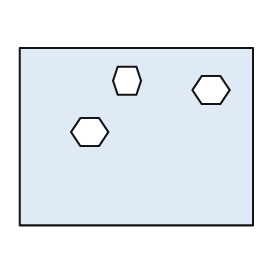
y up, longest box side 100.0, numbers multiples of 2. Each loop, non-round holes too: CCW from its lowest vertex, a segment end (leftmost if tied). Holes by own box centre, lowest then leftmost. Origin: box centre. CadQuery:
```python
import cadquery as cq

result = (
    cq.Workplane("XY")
    .moveTo(-50.0, -38.0)
    .lineTo(50.0, -38.0)
    .lineTo(50.0, 38.0)
    .lineTo(-50.0, 38.0)
    .close()
    .moveTo(-24.0, -4.0)
    .lineTo(-16.0, -4.0)
    .lineTo(-12.0, 2.0)
    .lineTo(-16.0, 8.0)
    .lineTo(-24.0, 8.0)
    .lineTo(-28.0, 2.0)
    .close()
    .moveTo(28.0, 14.0)
    .lineTo(36.0, 14.0)
    .lineTo(40.0, 20.0)
    .lineTo(36.0, 26.0)
    .lineTo(28.0, 26.0)
    .lineTo(24.0, 20.0)
    .close()
    .moveTo(-8.0, 18.0)
    .lineTo(0.0, 18.0)
    .lineTo(2.0, 24.0)
    .lineTo(0.0, 30.0)
    .lineTo(-8.0, 30.0)
    .lineTo(-10.0, 24.0)
    .close()
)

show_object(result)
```